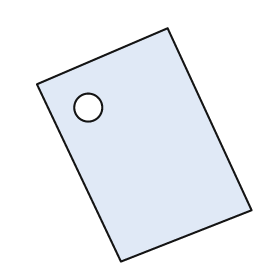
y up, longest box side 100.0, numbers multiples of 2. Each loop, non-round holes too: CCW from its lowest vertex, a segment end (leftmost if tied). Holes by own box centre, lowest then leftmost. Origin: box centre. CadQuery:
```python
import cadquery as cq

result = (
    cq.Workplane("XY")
    .moveTo(-10.0, -50.0)
    .lineTo(46.0, -28.0)
    .lineTo(10.0, 50.0)
    .lineTo(-46.0, 26.0)
    .close()
    .moveTo(-24.0, 16.0)
    .circle(6.0)
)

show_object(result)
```